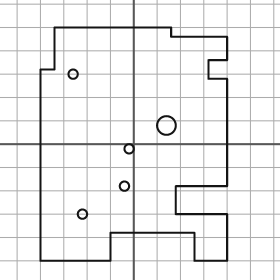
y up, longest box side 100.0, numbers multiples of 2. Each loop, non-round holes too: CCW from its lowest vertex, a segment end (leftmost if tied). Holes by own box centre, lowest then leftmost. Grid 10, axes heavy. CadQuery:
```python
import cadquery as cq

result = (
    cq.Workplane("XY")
    .moveTo(-40.0, -50.0)
    .lineTo(-10.0, -50.0)
    .lineTo(-10.0, -38.0)
    .lineTo(26.0, -38.0)
    .lineTo(26.0, -50.0)
    .lineTo(40.0, -50.0)
    .lineTo(40.0, -30.0)
    .lineTo(18.0, -30.0)
    .lineTo(18.0, -18.0)
    .lineTo(40.0, -18.0)
    .lineTo(40.0, 28.0)
    .lineTo(32.0, 28.0)
    .lineTo(32.0, 36.0)
    .lineTo(40.0, 36.0)
    .lineTo(40.0, 46.0)
    .lineTo(16.0, 46.0)
    .lineTo(16.0, 50.0)
    .lineTo(-34.0, 50.0)
    .lineTo(-34.0, 32.0)
    .lineTo(-40.0, 32.0)
    .close()
    .moveTo(-22.0, -30.0)
    .circle(2.0)
    .moveTo(-4.0, -18.0)
    .circle(2.0)
    .moveTo(-2.0, -2.0)
    .circle(2.0)
    .moveTo(14.0, 8.0)
    .circle(4.0)
    .moveTo(-26.0, 30.0)
    .circle(2.0)
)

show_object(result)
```